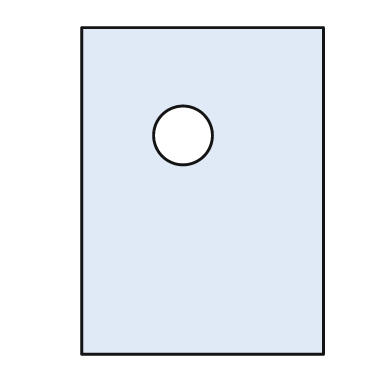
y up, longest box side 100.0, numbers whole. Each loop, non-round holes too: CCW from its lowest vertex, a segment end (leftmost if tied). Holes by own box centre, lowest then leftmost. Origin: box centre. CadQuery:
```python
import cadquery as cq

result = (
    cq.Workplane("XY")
    .moveTo(-37.0, -50.0)
    .lineTo(37.0, -50.0)
    .lineTo(37.0, 50.0)
    .lineTo(-37.0, 50.0)
    .close()
    .moveTo(-6.0, 17.0)
    .circle(9.0)
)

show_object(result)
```